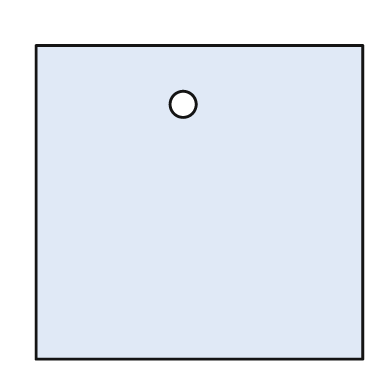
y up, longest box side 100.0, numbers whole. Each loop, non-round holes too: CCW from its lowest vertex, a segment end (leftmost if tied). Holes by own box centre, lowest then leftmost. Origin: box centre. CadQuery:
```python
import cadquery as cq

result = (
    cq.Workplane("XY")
    .moveTo(-50.0, -48.0)
    .lineTo(50.0, -48.0)
    .lineTo(50.0, 48.0)
    .lineTo(-50.0, 48.0)
    .close()
    .moveTo(-5.0, 30.0)
    .circle(4.0)
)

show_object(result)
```